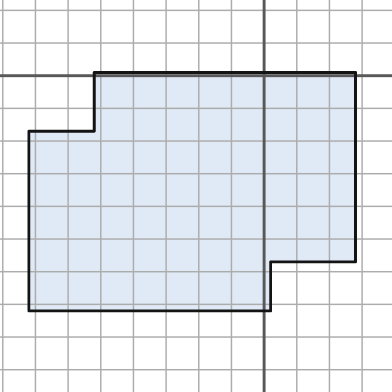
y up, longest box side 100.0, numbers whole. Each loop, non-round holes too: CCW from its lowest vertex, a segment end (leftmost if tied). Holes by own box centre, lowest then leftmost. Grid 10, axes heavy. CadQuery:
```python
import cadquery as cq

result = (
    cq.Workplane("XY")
    .moveTo(-72.0, -72.0)
    .lineTo(2.0, -72.0)
    .lineTo(2.0, -57.0)
    .lineTo(28.0, -57.0)
    .lineTo(28.0, 1.0)
    .lineTo(-52.0, 1.0)
    .lineTo(-52.0, -17.0)
    .lineTo(-72.0, -17.0)
    .close()
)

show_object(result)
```